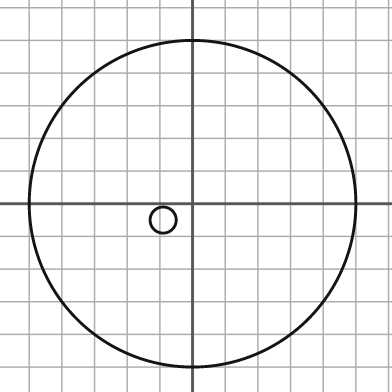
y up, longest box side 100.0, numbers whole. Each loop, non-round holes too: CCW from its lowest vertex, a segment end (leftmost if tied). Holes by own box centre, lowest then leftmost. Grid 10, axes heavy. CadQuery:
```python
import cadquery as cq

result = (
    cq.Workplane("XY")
    .moveTo(0.0, 0.0)
    .circle(50.0)
    .moveTo(-9.0, -5.0)
    .circle(4.0)
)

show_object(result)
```